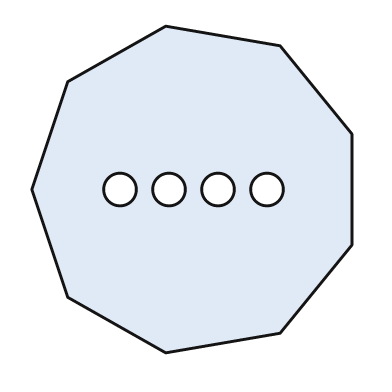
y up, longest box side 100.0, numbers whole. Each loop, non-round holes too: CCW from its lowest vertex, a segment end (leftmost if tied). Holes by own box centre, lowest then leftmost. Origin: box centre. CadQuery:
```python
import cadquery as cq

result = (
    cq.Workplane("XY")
    .moveTo(-8.0, -50.0)
    .lineTo(27.0, -44.0)
    .lineTo(49.0, -17.0)
    .lineTo(49.0, 17.0)
    .lineTo(27.0, 44.0)
    .lineTo(-8.0, 50.0)
    .lineTo(-38.0, 33.0)
    .lineTo(-49.0, 0.0)
    .lineTo(-38.0, -33.0)
    .close()
    .moveTo(-22.0, 0.0)
    .circle(5.0)
    .moveTo(-7.0, 0.0)
    .circle(5.0)
    .moveTo(8.0, 0.0)
    .circle(5.0)
    .moveTo(23.0, 0.0)
    .circle(5.0)
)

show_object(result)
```